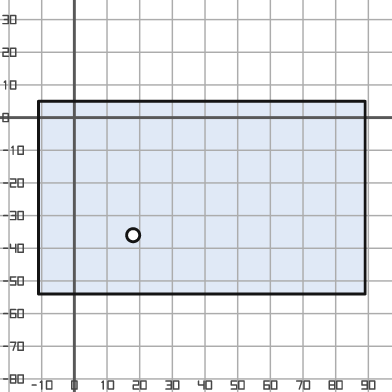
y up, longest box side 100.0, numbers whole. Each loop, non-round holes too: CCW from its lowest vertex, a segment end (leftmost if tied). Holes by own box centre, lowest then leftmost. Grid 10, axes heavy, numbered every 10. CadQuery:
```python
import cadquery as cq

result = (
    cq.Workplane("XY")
    .moveTo(-11.0, -54.0)
    .lineTo(89.0, -54.0)
    .lineTo(89.0, 5.0)
    .lineTo(-11.0, 5.0)
    .close()
    .moveTo(18.0, -36.0)
    .circle(2.0)
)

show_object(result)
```